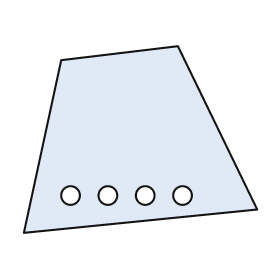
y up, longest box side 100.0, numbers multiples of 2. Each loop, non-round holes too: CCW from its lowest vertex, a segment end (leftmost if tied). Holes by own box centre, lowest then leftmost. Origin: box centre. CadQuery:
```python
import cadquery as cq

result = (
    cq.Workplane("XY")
    .moveTo(-50.0, -40.0)
    .lineTo(50.0, -30.0)
    .lineTo(16.0, 40.0)
    .lineTo(-34.0, 34.0)
    .close()
    .moveTo(-30.0, -24.0)
    .circle(4.0)
    .moveTo(-14.0, -24.0)
    .circle(4.0)
    .moveTo(2.0, -24.0)
    .circle(4.0)
    .moveTo(18.0, -24.0)
    .circle(4.0)
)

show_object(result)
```